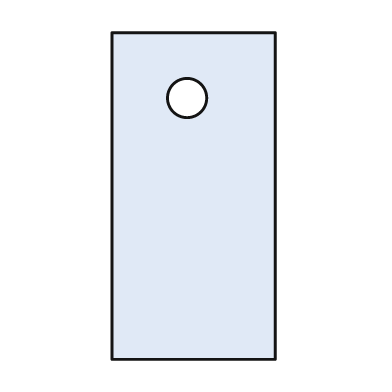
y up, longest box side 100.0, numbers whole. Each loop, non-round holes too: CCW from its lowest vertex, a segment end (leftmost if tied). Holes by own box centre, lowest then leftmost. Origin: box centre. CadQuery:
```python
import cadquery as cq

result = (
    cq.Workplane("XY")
    .moveTo(-25.0, -50.0)
    .lineTo(25.0, -50.0)
    .lineTo(25.0, 50.0)
    .lineTo(-25.0, 50.0)
    .close()
    .moveTo(-2.0, 30.0)
    .circle(6.0)
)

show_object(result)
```